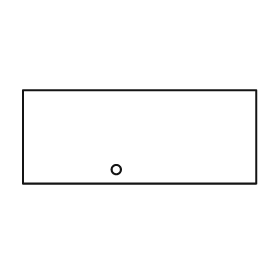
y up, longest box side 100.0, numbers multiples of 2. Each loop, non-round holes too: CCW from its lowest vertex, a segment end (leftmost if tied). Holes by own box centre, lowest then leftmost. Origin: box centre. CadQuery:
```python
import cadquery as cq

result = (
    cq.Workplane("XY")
    .moveTo(-50.0, -20.0)
    .lineTo(50.0, -20.0)
    .lineTo(50.0, 20.0)
    .lineTo(-50.0, 20.0)
    .close()
    .moveTo(-10.0, -14.0)
    .circle(2.0)
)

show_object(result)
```